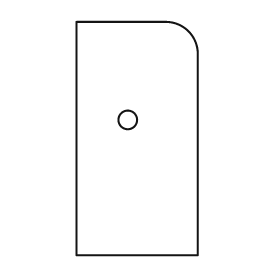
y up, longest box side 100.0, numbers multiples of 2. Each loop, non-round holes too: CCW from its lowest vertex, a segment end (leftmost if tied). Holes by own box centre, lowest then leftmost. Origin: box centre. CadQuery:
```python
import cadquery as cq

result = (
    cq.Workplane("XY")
    .moveTo(-26.0, -50.0)
    .lineTo(26.0, -50.0)
    .lineTo(26.0, 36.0)
    .threePointArc((22.0, 46.0), (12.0, 50.0))
    .lineTo(-26.0, 50.0)
    .close()
    .moveTo(-4.0, 8.0)
    .circle(4.0)
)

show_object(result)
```